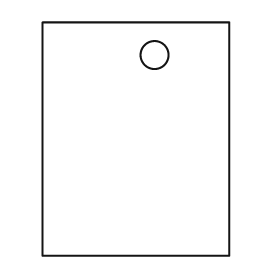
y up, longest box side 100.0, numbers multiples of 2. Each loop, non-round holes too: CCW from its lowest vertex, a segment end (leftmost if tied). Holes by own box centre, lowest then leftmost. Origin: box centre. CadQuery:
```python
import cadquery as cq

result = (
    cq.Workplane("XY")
    .moveTo(-40.0, -50.0)
    .lineTo(40.0, -50.0)
    .lineTo(40.0, 50.0)
    .lineTo(-40.0, 50.0)
    .close()
    .moveTo(8.0, 36.0)
    .circle(6.0)
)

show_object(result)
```